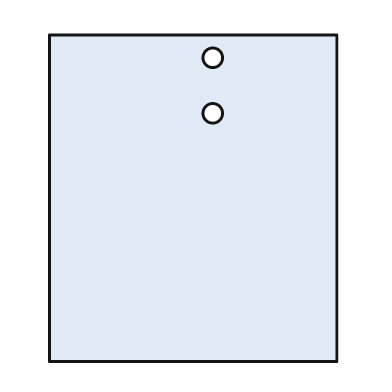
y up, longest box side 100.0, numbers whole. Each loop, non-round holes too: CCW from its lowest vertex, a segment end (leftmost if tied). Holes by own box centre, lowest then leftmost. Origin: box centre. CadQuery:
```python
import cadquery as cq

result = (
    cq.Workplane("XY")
    .moveTo(-44.0, -50.0)
    .lineTo(44.0, -50.0)
    .lineTo(44.0, 50.0)
    .lineTo(-44.0, 50.0)
    .close()
    .moveTo(6.0, 26.0)
    .circle(3.0)
    .moveTo(6.0, 43.0)
    .circle(3.0)
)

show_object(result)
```